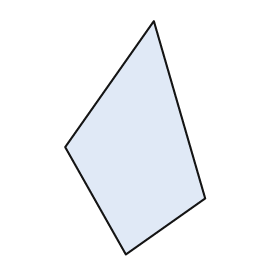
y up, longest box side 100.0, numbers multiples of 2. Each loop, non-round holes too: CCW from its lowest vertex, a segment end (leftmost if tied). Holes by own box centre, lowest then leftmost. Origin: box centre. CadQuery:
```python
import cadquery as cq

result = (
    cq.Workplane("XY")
    .moveTo(-4.0, -50.0)
    .lineTo(30.0, -26.0)
    .lineTo(8.0, 50.0)
    .lineTo(-30.0, -4.0)
    .close()
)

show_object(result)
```